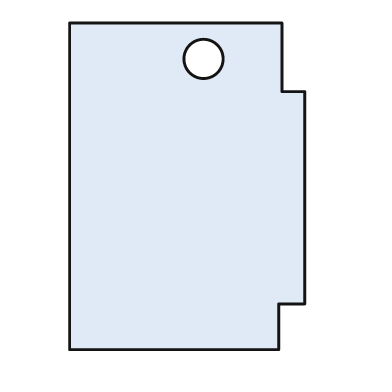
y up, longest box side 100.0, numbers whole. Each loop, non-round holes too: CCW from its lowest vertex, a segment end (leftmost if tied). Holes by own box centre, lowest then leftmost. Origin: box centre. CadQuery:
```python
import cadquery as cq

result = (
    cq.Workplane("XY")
    .moveTo(-36.0, -50.0)
    .lineTo(28.0, -50.0)
    .lineTo(28.0, -36.0)
    .lineTo(36.0, -36.0)
    .lineTo(36.0, 29.0)
    .lineTo(29.0, 29.0)
    .lineTo(29.0, 50.0)
    .lineTo(-36.0, 50.0)
    .close()
    .moveTo(5.0, 39.0)
    .circle(6.0)
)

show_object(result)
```